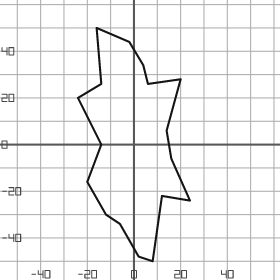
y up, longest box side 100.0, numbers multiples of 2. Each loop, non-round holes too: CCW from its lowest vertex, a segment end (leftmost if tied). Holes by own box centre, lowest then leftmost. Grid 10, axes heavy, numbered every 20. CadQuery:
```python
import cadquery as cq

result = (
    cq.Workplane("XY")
    .moveTo(8.0, -50.0)
    .lineTo(12.0, -22.0)
    .lineTo(24.0, -24.0)
    .lineTo(16.0, -6.0)
    .lineTo(14.0, 6.0)
    .lineTo(20.0, 28.0)
    .lineTo(6.0, 26.0)
    .lineTo(4.0, 34.0)
    .lineTo(-2.0, 44.0)
    .lineTo(-16.0, 50.0)
    .lineTo(-14.0, 26.0)
    .lineTo(-24.0, 20.0)
    .lineTo(-14.0, 0.0)
    .lineTo(-20.0, -16.0)
    .lineTo(-12.0, -30.0)
    .lineTo(-6.0, -34.0)
    .lineTo(2.0, -48.0)
    .close()
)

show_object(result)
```